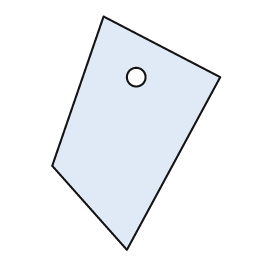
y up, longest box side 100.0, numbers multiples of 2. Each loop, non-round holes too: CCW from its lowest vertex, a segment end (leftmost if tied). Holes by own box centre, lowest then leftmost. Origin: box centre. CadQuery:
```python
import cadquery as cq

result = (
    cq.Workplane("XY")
    .moveTo(-4.0, -50.0)
    .lineTo(36.0, 24.0)
    .lineTo(-14.0, 50.0)
    .lineTo(-36.0, -14.0)
    .close()
    .moveTo(0.0, 24.0)
    .circle(4.0)
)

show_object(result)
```